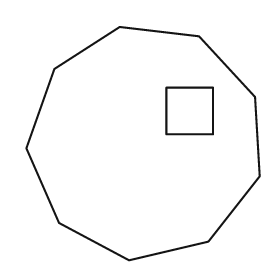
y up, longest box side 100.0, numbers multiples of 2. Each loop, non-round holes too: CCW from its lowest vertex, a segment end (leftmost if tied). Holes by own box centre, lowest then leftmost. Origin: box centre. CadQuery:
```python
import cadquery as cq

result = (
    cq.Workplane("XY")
    .moveTo(-6.0, -50.0)
    .lineTo(28.0, -42.0)
    .lineTo(50.0, -14.0)
    .lineTo(48.0, 20.0)
    .lineTo(24.0, 46.0)
    .lineTo(-10.0, 50.0)
    .lineTo(-38.0, 32.0)
    .lineTo(-50.0, -2.0)
    .lineTo(-36.0, -34.0)
    .close()
    .moveTo(10.0, 4.0)
    .lineTo(30.0, 4.0)
    .lineTo(30.0, 24.0)
    .lineTo(10.0, 24.0)
    .close()
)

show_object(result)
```